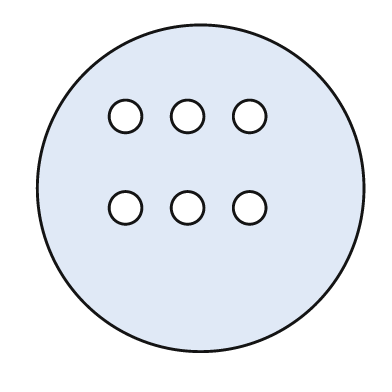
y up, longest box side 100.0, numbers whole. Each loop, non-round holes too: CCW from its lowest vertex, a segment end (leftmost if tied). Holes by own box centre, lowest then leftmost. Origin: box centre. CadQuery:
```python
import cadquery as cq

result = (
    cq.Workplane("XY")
    .moveTo(0.0, 0.0)
    .circle(50.0)
    .moveTo(-23.0, -6.0)
    .circle(5.0)
    .moveTo(-4.0, -6.0)
    .circle(5.0)
    .moveTo(15.0, -6.0)
    .circle(5.0)
    .moveTo(-23.0, 22.0)
    .circle(5.0)
    .moveTo(-4.0, 22.0)
    .circle(5.0)
    .moveTo(15.0, 22.0)
    .circle(5.0)
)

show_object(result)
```